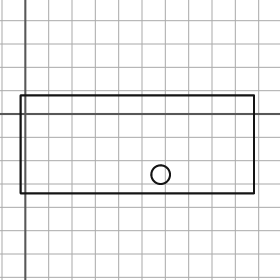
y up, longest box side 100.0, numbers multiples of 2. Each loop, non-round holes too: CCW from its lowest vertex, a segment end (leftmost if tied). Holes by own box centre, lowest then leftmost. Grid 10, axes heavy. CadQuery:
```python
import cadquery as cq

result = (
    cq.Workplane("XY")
    .moveTo(-2.0, -34.0)
    .lineTo(98.0, -34.0)
    .lineTo(98.0, 8.0)
    .lineTo(-2.0, 8.0)
    .close()
    .moveTo(58.0, -26.0)
    .circle(4.0)
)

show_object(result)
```